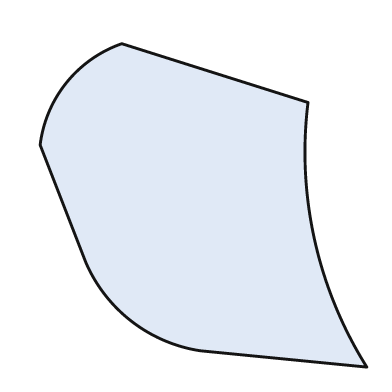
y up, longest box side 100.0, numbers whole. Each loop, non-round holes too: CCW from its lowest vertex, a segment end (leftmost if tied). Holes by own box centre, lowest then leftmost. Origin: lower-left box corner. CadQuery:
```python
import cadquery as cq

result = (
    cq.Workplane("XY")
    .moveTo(100.0, 0.0)
    .threePointArc((84.0, 39.0), (82.0, 81.0))
    .lineTo(25.0, 99.0)
    .threePointArc((8.0, 87.0), (0.0, 68.0))
    .lineTo(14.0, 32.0)
    .threePointArc((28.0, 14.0), (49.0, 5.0))
    .close()
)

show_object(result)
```